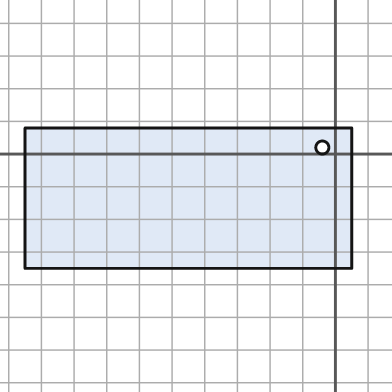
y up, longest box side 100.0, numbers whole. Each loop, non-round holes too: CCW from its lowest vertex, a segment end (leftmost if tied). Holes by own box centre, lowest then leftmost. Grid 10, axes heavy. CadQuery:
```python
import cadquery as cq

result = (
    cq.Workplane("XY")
    .moveTo(-95.0, -35.0)
    .lineTo(5.0, -35.0)
    .lineTo(5.0, 8.0)
    .lineTo(-95.0, 8.0)
    .close()
    .moveTo(-4.0, 2.0)
    .circle(2.0)
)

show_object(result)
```